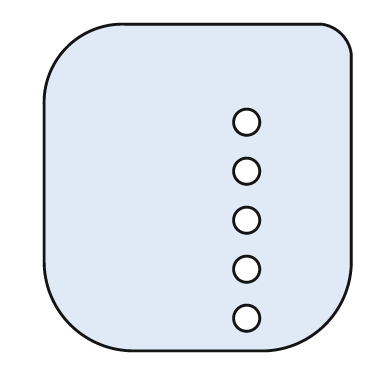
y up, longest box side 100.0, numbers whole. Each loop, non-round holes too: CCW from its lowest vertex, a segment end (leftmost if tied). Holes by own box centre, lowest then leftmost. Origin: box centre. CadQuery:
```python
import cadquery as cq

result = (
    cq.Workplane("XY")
    .moveTo(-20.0, -50.0)
    .lineTo(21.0, -50.0)
    .threePointArc((39.0, -42.0), (47.0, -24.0))
    .lineTo(47.0, 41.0)
    .threePointArc((44.0, 47.0), (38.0, 50.0))
    .lineTo(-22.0, 50.0)
    .threePointArc((-40.0, 43.0), (-47.0, 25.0))
    .lineTo(-47.0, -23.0)
    .threePointArc((-39.0, -42.0), (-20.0, -50.0))
    .close()
    .moveTo(15.0, -40.0)
    .circle(4.0)
    .moveTo(15.0, -25.0)
    .circle(4.0)
    .moveTo(15.0, -10.0)
    .circle(4.0)
    .moveTo(15.0, 5.0)
    .circle(4.0)
    .moveTo(15.0, 20.0)
    .circle(4.0)
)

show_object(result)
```